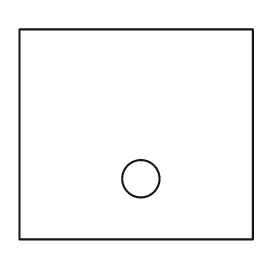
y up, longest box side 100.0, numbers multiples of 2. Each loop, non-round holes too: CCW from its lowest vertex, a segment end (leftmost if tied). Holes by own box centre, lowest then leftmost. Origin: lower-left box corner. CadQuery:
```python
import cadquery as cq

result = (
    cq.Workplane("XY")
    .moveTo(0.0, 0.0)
    .lineTo(100.0, 0.0)
    .lineTo(100.0, 90.0)
    .lineTo(0.0, 90.0)
    .close()
    .moveTo(52.0, 26.0)
    .circle(8.0)
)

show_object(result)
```